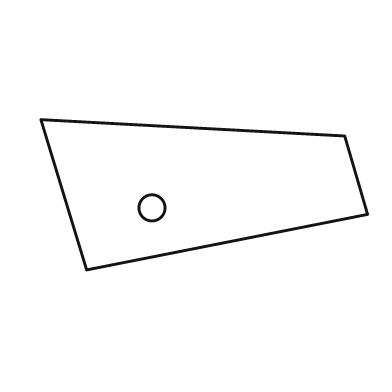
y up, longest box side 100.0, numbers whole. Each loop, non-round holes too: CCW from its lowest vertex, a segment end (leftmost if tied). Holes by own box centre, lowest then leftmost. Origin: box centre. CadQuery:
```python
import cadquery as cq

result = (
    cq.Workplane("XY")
    .moveTo(-36.0, -23.0)
    .lineTo(50.0, -6.0)
    .lineTo(43.0, 18.0)
    .lineTo(-50.0, 23.0)
    .close()
    .moveTo(-16.0, -4.0)
    .circle(4.0)
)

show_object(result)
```